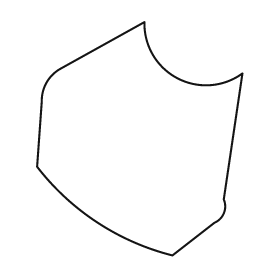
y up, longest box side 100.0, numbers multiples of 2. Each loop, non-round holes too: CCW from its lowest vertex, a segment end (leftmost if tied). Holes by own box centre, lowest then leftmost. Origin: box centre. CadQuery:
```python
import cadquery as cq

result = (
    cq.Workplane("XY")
    .moveTo(14.0, -50.0)
    .lineTo(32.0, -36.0)
    .threePointArc((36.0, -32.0), (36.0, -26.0))
    .lineTo(44.0, 28.0)
    .threePointArc((16.0, 26.0), (2.0, 50.0))
    .lineTo(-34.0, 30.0)
    .threePointArc((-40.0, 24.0), (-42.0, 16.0))
    .lineTo(-44.0, -12.0)
    .threePointArc((-18.0, -36.0), (14.0, -50.0))
    .close()
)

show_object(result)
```